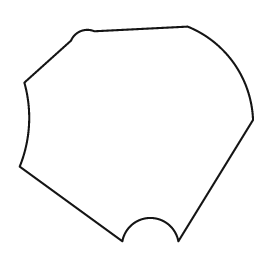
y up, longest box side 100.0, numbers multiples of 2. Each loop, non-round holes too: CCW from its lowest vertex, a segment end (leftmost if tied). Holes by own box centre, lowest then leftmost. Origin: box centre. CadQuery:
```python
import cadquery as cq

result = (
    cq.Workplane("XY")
    .moveTo(-6.0, -46.0)
    .threePointArc((6.0, -36.0), (18.0, -46.0))
    .lineTo(50.0, 6.0)
    .threePointArc((42.0, 30.0), (22.0, 46.0))
    .lineTo(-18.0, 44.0)
    .threePointArc((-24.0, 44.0), (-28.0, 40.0))
    .lineTo(-48.0, 22.0)
    .threePointArc((-46.0, 4.0), (-50.0, -14.0))
    .close()
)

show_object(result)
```